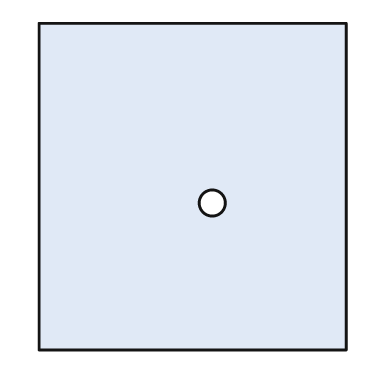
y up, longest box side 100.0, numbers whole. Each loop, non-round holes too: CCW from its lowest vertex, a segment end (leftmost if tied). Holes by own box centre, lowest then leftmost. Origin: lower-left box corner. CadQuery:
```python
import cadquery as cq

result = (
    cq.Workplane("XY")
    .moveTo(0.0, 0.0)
    .lineTo(94.0, 0.0)
    .lineTo(94.0, 100.0)
    .lineTo(0.0, 100.0)
    .close()
    .moveTo(53.0, 45.0)
    .circle(4.0)
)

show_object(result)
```